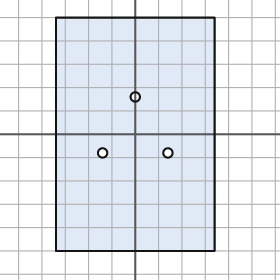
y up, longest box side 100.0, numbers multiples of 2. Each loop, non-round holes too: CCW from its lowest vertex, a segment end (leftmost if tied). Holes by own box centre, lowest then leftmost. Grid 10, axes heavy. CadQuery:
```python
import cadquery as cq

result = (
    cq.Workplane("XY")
    .moveTo(-34.0, -50.0)
    .lineTo(34.0, -50.0)
    .lineTo(34.0, 50.0)
    .lineTo(-34.0, 50.0)
    .close()
    .moveTo(-14.0, -8.0)
    .circle(2.0)
    .moveTo(14.0, -8.0)
    .circle(2.0)
    .moveTo(0.0, 16.0)
    .circle(2.0)
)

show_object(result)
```